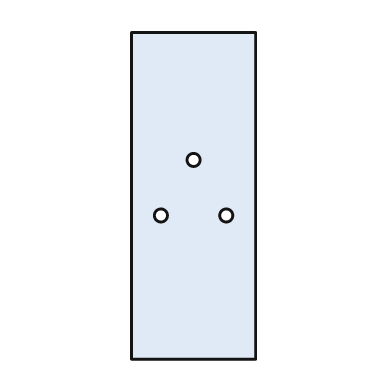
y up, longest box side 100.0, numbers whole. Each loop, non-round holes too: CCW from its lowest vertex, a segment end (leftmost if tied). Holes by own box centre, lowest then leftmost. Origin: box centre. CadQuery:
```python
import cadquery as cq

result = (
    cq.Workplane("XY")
    .moveTo(-19.0, -50.0)
    .lineTo(19.0, -50.0)
    .lineTo(19.0, 50.0)
    .lineTo(-19.0, 50.0)
    .close()
    .moveTo(-10.0, -6.0)
    .circle(2.0)
    .moveTo(10.0, -6.0)
    .circle(2.0)
    .moveTo(0.0, 11.0)
    .circle(2.0)
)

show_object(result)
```